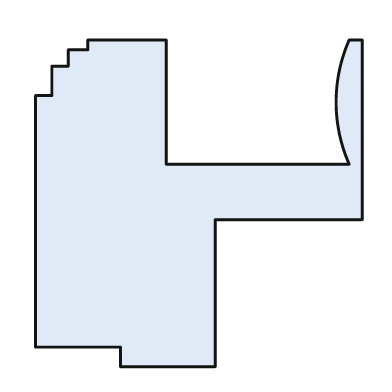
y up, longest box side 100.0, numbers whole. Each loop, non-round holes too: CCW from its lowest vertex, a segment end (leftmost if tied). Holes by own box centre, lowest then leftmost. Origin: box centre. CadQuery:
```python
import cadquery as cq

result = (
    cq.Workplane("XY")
    .moveTo(-24.0, -50.0)
    .lineTo(5.0, -50.0)
    .lineTo(5.0, -5.0)
    .lineTo(50.0, -5.0)
    .lineTo(50.0, 50.0)
    .lineTo(46.0, 50.0)
    .threePointArc((42.0, 31.0), (46.0, 12.0))
    .lineTo(-10.0, 12.0)
    .lineTo(-10.0, 50.0)
    .lineTo(-34.0, 50.0)
    .lineTo(-34.0, 47.0)
    .lineTo(-40.0, 47.0)
    .lineTo(-40.0, 42.0)
    .lineTo(-45.0, 42.0)
    .lineTo(-45.0, 33.0)
    .lineTo(-50.0, 33.0)
    .lineTo(-50.0, -44.0)
    .lineTo(-24.0, -44.0)
    .close()
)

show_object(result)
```